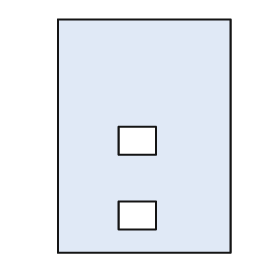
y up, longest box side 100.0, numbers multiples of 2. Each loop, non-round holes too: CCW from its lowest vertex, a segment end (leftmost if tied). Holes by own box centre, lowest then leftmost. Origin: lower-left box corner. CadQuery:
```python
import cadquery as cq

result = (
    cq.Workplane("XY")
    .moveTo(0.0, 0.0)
    .lineTo(74.0, 0.0)
    .lineTo(74.0, 100.0)
    .lineTo(0.0, 100.0)
    .close()
    .moveTo(26.0, 10.0)
    .lineTo(42.0, 10.0)
    .lineTo(42.0, 22.0)
    .lineTo(26.0, 22.0)
    .close()
    .moveTo(26.0, 42.0)
    .lineTo(42.0, 42.0)
    .lineTo(42.0, 54.0)
    .lineTo(26.0, 54.0)
    .close()
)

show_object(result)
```